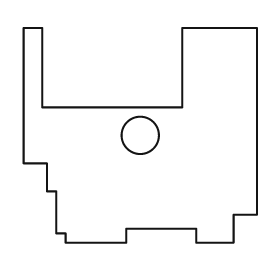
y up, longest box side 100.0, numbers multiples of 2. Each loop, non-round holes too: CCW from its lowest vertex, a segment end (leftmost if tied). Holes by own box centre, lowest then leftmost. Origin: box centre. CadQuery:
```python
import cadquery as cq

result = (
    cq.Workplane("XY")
    .moveTo(-32.0, -46.0)
    .lineTo(-6.0, -46.0)
    .lineTo(-6.0, -40.0)
    .lineTo(24.0, -40.0)
    .lineTo(24.0, -46.0)
    .lineTo(40.0, -46.0)
    .lineTo(40.0, -34.0)
    .lineTo(50.0, -34.0)
    .lineTo(50.0, 46.0)
    .lineTo(18.0, 46.0)
    .lineTo(18.0, 12.0)
    .lineTo(-42.0, 12.0)
    .lineTo(-42.0, 46.0)
    .lineTo(-50.0, 46.0)
    .lineTo(-50.0, -12.0)
    .lineTo(-40.0, -12.0)
    .lineTo(-40.0, -24.0)
    .lineTo(-36.0, -24.0)
    .lineTo(-36.0, -42.0)
    .lineTo(-32.0, -42.0)
    .close()
    .moveTo(0.0, 0.0)
    .circle(8.0)
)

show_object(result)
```